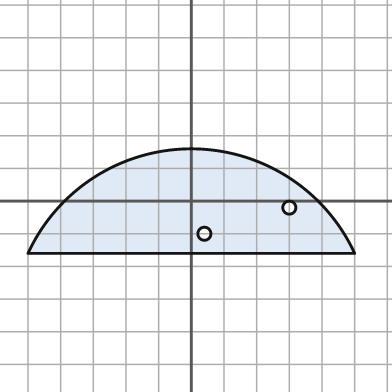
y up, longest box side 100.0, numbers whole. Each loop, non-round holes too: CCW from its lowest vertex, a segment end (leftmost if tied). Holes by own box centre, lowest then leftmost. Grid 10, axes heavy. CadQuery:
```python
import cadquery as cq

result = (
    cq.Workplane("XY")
    .moveTo(-50.0, -16.0)
    .lineTo(50.0, -16.0)
    .threePointArc((0.0, 16.0), (-50.0, -16.0))
    .close()
    .moveTo(4.0, -10.0)
    .circle(2.0)
    .moveTo(30.0, -2.0)
    .circle(2.0)
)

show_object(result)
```